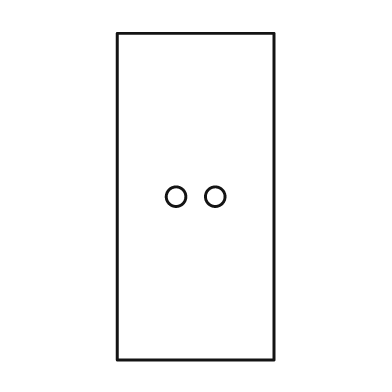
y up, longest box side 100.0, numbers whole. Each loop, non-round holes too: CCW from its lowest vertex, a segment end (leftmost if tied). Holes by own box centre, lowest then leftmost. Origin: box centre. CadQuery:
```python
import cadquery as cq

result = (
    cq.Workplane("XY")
    .moveTo(-24.0, -50.0)
    .lineTo(24.0, -50.0)
    .lineTo(24.0, 50.0)
    .lineTo(-24.0, 50.0)
    .close()
    .moveTo(-6.0, 0.0)
    .circle(3.0)
    .moveTo(6.0, 0.0)
    .circle(3.0)
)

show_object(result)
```